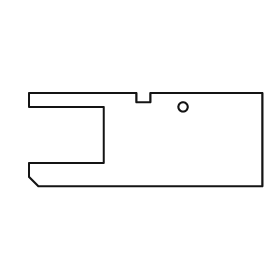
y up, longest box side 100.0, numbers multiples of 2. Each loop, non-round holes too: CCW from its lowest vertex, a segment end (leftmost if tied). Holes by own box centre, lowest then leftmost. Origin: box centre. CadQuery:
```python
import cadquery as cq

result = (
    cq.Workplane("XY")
    .moveTo(-46.0, -20.0)
    .lineTo(50.0, -20.0)
    .lineTo(50.0, 20.0)
    .lineTo(2.0, 20.0)
    .lineTo(2.0, 16.0)
    .lineTo(-4.0, 16.0)
    .lineTo(-4.0, 20.0)
    .lineTo(-50.0, 20.0)
    .lineTo(-50.0, 14.0)
    .lineTo(-18.0, 14.0)
    .lineTo(-18.0, -10.0)
    .lineTo(-50.0, -10.0)
    .lineTo(-50.0, -16.0)
    .close()
    .moveTo(16.0, 14.0)
    .circle(2.0)
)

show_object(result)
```